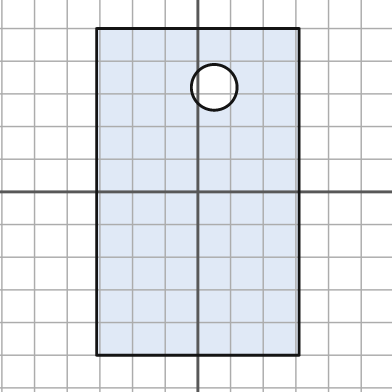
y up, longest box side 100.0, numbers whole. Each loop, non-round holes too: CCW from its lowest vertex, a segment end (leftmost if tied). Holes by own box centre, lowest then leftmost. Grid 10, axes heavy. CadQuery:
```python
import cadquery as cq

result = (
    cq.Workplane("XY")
    .moveTo(-31.0, -50.0)
    .lineTo(31.0, -50.0)
    .lineTo(31.0, 50.0)
    .lineTo(-31.0, 50.0)
    .close()
    .moveTo(5.0, 32.0)
    .circle(7.0)
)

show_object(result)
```